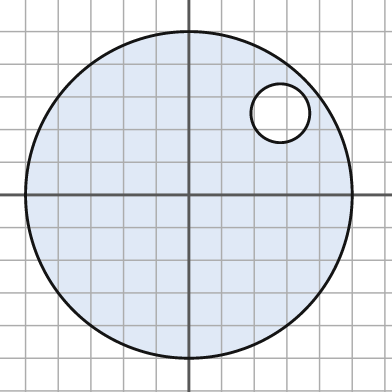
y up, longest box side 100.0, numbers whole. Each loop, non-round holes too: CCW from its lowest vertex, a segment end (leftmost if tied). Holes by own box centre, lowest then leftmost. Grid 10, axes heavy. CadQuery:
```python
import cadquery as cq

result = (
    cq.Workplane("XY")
    .moveTo(0.0, 0.0)
    .circle(50.0)
    .moveTo(28.0, 25.0)
    .circle(9.0)
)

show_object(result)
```